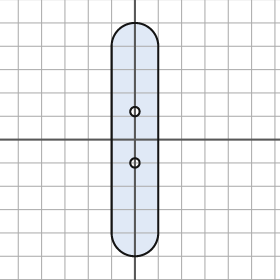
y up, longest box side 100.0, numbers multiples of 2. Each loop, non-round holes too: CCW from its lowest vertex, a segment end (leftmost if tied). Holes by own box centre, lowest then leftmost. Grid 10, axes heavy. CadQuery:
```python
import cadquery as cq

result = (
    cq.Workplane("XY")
    .moveTo(-10.0, -40.0)
    .threePointArc((0.0, -50.0), (10.0, -40.0))
    .lineTo(10.0, 40.0)
    .threePointArc((0.0, 50.0), (-10.0, 40.0))
    .close()
    .moveTo(0.0, -10.0)
    .circle(2.0)
    .moveTo(0.0, 12.0)
    .circle(2.0)
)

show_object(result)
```